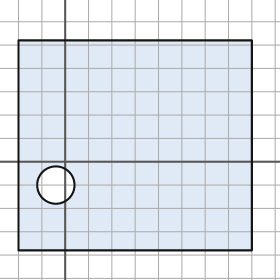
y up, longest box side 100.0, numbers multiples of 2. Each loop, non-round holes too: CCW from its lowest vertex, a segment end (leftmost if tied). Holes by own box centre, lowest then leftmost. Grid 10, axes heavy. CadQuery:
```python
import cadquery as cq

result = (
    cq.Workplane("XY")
    .moveTo(-20.0, -38.0)
    .lineTo(80.0, -38.0)
    .lineTo(80.0, 52.0)
    .lineTo(-20.0, 52.0)
    .close()
    .moveTo(-4.0, -10.0)
    .circle(8.0)
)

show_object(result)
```